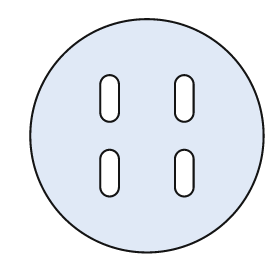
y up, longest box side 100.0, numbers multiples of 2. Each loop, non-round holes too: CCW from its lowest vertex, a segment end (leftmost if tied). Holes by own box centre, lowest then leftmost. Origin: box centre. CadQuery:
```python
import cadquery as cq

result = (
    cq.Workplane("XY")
    .moveTo(0.0, 0.0)
    .circle(50.0)
    .moveTo(-20.0, -22.0)
    .threePointArc((-16.0, -26.0), (-12.0, -22.0))
    .lineTo(-12.0, -10.0)
    .threePointArc((-16.0, -6.0), (-20.0, -10.0))
    .close()
    .moveTo(12.0, -22.0)
    .threePointArc((16.0, -26.0), (20.0, -22.0))
    .lineTo(20.0, -10.0)
    .threePointArc((16.0, -6.0), (12.0, -10.0))
    .close()
    .moveTo(-20.0, 10.0)
    .threePointArc((-16.0, 6.0), (-12.0, 10.0))
    .lineTo(-12.0, 22.0)
    .threePointArc((-16.0, 26.0), (-20.0, 22.0))
    .close()
    .moveTo(12.0, 10.0)
    .threePointArc((16.0, 6.0), (20.0, 10.0))
    .lineTo(20.0, 22.0)
    .threePointArc((16.0, 26.0), (12.0, 22.0))
    .close()
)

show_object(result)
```